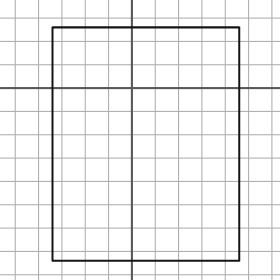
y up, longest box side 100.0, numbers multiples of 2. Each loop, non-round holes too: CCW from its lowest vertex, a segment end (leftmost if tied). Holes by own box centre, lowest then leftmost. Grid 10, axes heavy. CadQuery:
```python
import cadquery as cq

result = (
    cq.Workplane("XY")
    .moveTo(-34.0, -74.0)
    .lineTo(46.0, -74.0)
    .lineTo(46.0, 26.0)
    .lineTo(-34.0, 26.0)
    .close()
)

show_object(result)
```